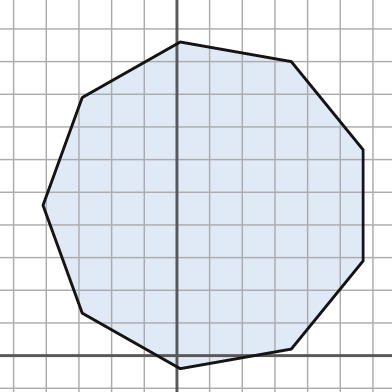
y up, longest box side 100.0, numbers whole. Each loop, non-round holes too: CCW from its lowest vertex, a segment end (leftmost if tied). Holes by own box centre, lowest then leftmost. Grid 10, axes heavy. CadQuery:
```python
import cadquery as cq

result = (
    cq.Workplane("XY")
    .moveTo(1.0, -4.0)
    .lineTo(35.0, 2.0)
    .lineTo(57.0, 29.0)
    .lineTo(57.0, 63.0)
    .lineTo(35.0, 90.0)
    .lineTo(1.0, 96.0)
    .lineTo(-29.0, 79.0)
    .lineTo(-41.0, 46.0)
    .lineTo(-29.0, 13.0)
    .close()
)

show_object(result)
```